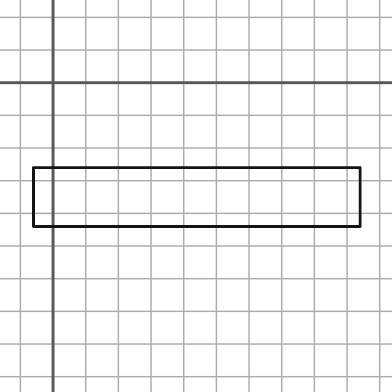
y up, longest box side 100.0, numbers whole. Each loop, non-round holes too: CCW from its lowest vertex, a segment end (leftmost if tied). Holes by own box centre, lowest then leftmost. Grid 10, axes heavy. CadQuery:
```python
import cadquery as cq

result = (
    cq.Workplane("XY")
    .moveTo(-6.0, -44.0)
    .lineTo(94.0, -44.0)
    .lineTo(94.0, -26.0)
    .lineTo(-6.0, -26.0)
    .close()
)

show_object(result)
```